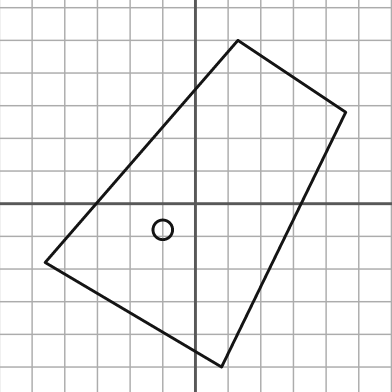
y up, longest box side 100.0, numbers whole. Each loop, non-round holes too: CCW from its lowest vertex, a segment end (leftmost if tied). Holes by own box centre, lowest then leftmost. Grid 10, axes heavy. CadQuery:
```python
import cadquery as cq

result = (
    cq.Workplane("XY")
    .moveTo(8.0, -50.0)
    .lineTo(46.0, 28.0)
    .lineTo(13.0, 50.0)
    .lineTo(-46.0, -18.0)
    .close()
    .moveTo(-10.0, -8.0)
    .circle(3.0)
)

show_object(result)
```